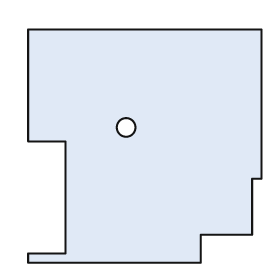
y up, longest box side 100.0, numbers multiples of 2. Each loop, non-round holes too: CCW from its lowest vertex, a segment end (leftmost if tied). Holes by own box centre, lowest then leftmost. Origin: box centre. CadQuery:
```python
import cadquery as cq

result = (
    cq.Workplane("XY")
    .moveTo(-50.0, -50.0)
    .lineTo(24.0, -50.0)
    .lineTo(24.0, -38.0)
    .lineTo(46.0, -38.0)
    .lineTo(46.0, -14.0)
    .lineTo(50.0, -14.0)
    .lineTo(50.0, 50.0)
    .lineTo(-50.0, 50.0)
    .lineTo(-50.0, 2.0)
    .lineTo(-34.0, 2.0)
    .lineTo(-34.0, -46.0)
    .lineTo(-50.0, -46.0)
    .close()
    .moveTo(-8.0, 8.0)
    .circle(4.0)
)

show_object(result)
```